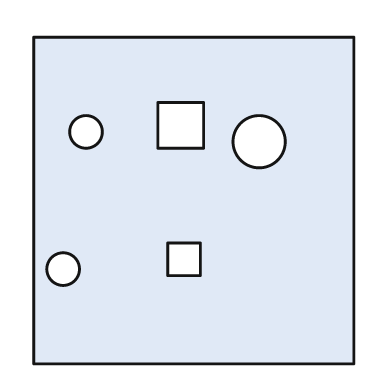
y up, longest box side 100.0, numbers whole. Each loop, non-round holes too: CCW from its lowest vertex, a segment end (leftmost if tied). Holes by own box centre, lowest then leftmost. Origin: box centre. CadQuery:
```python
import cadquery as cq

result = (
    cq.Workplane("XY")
    .moveTo(-49.0, -50.0)
    .lineTo(49.0, -50.0)
    .lineTo(49.0, 50.0)
    .lineTo(-49.0, 50.0)
    .close()
    .moveTo(-40.0, -21.0)
    .circle(5.0)
    .moveTo(-8.0, -23.0)
    .lineTo(2.0, -23.0)
    .lineTo(2.0, -13.0)
    .lineTo(-8.0, -13.0)
    .close()
    .moveTo(20.0, 18.0)
    .circle(8.0)
    .moveTo(-33.0, 21.0)
    .circle(5.0)
    .moveTo(-11.0, 16.0)
    .lineTo(3.0, 16.0)
    .lineTo(3.0, 30.0)
    .lineTo(-11.0, 30.0)
    .close()
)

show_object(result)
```